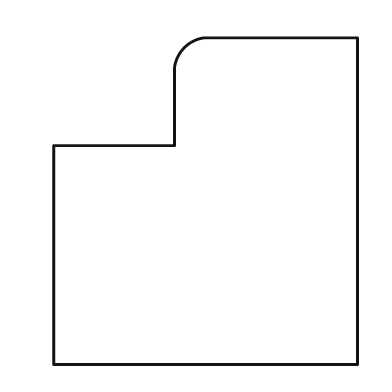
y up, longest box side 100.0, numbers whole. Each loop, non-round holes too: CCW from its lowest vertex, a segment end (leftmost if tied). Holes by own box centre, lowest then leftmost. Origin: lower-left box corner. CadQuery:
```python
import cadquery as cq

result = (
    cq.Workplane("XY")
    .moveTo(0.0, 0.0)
    .lineTo(93.0, 0.0)
    .lineTo(93.0, 100.0)
    .lineTo(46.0, 100.0)
    .threePointArc((40.0, 97.0), (37.0, 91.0))
    .lineTo(37.0, 67.0)
    .lineTo(0.0, 67.0)
    .close()
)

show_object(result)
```